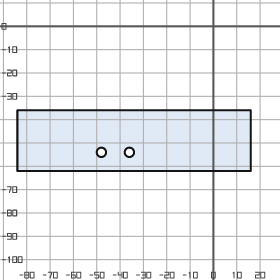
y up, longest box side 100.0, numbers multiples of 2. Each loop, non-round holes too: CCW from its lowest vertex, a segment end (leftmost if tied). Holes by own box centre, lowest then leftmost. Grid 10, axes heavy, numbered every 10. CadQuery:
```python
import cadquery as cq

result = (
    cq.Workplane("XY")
    .moveTo(-84.0, -62.0)
    .lineTo(16.0, -62.0)
    .lineTo(16.0, -36.0)
    .lineTo(-84.0, -36.0)
    .close()
    .moveTo(-48.0, -54.0)
    .circle(2.0)
    .moveTo(-36.0, -54.0)
    .circle(2.0)
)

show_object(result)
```